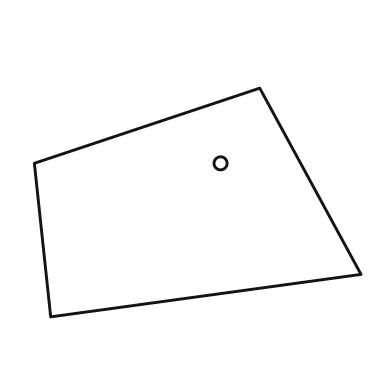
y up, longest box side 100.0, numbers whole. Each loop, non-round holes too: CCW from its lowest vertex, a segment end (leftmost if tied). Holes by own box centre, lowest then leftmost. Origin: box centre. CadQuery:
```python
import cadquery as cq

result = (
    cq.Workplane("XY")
    .moveTo(-45.0, -35.0)
    .lineTo(50.0, -22.0)
    .lineTo(19.0, 35.0)
    .lineTo(-50.0, 12.0)
    .close()
    .moveTo(7.0, 12.0)
    .circle(2.0)
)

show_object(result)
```